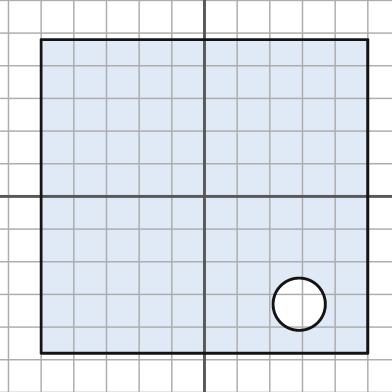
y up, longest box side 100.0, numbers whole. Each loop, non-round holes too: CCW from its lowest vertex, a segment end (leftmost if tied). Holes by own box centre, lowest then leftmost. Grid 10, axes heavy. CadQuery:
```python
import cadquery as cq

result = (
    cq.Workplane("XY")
    .moveTo(-50.0, -48.0)
    .lineTo(50.0, -48.0)
    .lineTo(50.0, 48.0)
    .lineTo(-50.0, 48.0)
    .close()
    .moveTo(29.0, -33.0)
    .circle(8.0)
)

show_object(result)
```